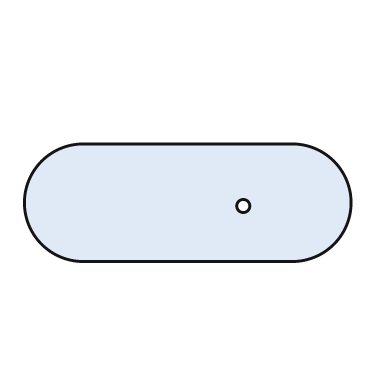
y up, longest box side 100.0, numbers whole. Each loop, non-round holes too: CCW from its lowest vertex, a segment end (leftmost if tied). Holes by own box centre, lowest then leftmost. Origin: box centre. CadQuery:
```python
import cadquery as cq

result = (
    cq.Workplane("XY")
    .moveTo(-32.0, -18.0)
    .lineTo(32.0, -18.0)
    .threePointArc((50.0, 0.0), (32.0, 18.0))
    .lineTo(-32.0, 18.0)
    .threePointArc((-50.0, 0.0), (-32.0, -18.0))
    .close()
    .moveTo(17.0, -1.0)
    .circle(2.0)
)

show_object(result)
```